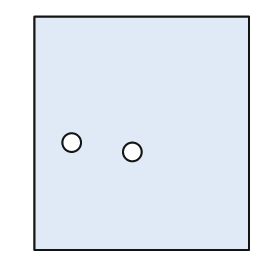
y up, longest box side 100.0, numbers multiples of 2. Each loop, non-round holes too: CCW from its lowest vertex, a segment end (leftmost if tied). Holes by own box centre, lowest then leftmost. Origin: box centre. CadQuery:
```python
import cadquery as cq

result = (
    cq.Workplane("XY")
    .moveTo(-46.0, -50.0)
    .lineTo(46.0, -50.0)
    .lineTo(46.0, 50.0)
    .lineTo(-46.0, 50.0)
    .close()
    .moveTo(-4.0, -8.0)
    .circle(4.0)
    .moveTo(-30.0, -4.0)
    .circle(4.0)
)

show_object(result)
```